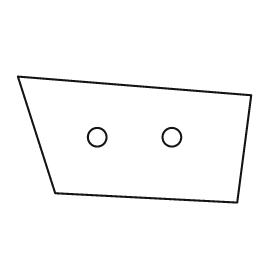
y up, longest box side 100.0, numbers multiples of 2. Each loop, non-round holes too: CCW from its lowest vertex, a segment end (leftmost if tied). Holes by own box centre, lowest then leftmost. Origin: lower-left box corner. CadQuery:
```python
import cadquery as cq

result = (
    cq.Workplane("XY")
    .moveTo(94.0, 0.0)
    .lineTo(100.0, 46.0)
    .lineTo(0.0, 54.0)
    .lineTo(16.0, 4.0)
    .close()
    .moveTo(34.0, 28.0)
    .circle(4.0)
    .moveTo(66.0, 28.0)
    .circle(4.0)
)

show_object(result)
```